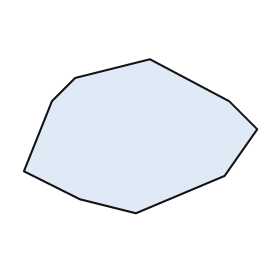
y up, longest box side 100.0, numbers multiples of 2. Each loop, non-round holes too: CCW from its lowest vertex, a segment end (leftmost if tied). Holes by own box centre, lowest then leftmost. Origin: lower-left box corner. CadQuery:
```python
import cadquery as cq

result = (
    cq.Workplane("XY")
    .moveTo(48.0, 0.0)
    .lineTo(86.0, 16.0)
    .lineTo(100.0, 36.0)
    .lineTo(88.0, 48.0)
    .lineTo(54.0, 66.0)
    .lineTo(22.0, 58.0)
    .lineTo(12.0, 48.0)
    .lineTo(0.0, 18.0)
    .lineTo(24.0, 6.0)
    .close()
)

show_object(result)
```